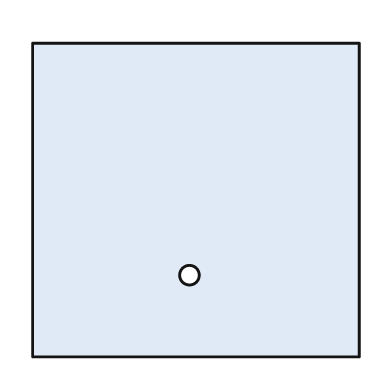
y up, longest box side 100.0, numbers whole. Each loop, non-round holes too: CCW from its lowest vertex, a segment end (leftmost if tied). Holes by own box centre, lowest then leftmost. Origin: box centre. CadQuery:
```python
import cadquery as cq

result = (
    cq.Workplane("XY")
    .moveTo(-50.0, -48.0)
    .lineTo(50.0, -48.0)
    .lineTo(50.0, 48.0)
    .lineTo(-50.0, 48.0)
    .close()
    .moveTo(-2.0, -23.0)
    .circle(3.0)
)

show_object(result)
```